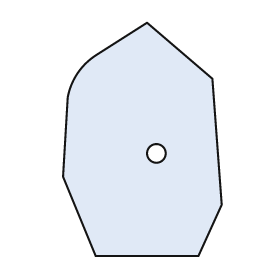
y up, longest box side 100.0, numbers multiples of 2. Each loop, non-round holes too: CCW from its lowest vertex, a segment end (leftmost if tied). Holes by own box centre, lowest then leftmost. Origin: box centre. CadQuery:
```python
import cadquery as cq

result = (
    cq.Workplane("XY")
    .moveTo(-20.0, -50.0)
    .lineTo(24.0, -50.0)
    .lineTo(34.0, -28.0)
    .lineTo(30.0, 26.0)
    .lineTo(2.0, 50.0)
    .lineTo(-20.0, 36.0)
    .threePointArc((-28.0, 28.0), (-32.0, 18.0))
    .lineTo(-34.0, -16.0)
    .close()
    .moveTo(6.0, -6.0)
    .circle(4.0)
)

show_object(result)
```